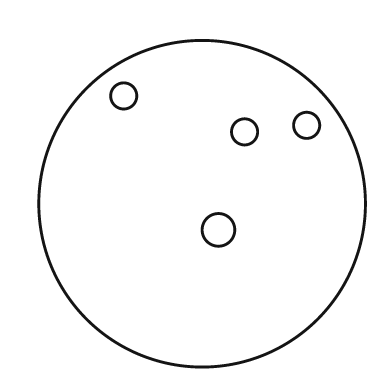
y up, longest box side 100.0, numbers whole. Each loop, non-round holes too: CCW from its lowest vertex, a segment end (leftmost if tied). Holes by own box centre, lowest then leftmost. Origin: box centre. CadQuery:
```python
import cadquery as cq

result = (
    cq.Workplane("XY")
    .moveTo(0.0, 0.0)
    .circle(50.0)
    .moveTo(5.0, -8.0)
    .circle(5.0)
    .moveTo(13.0, 22.0)
    .circle(4.0)
    .moveTo(32.0, 24.0)
    .circle(4.0)
    .moveTo(-24.0, 33.0)
    .circle(4.0)
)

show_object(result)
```